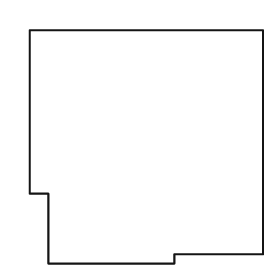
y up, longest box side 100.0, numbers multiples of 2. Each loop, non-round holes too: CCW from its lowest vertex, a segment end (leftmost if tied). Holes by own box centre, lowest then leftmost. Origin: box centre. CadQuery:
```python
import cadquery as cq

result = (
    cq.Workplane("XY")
    .moveTo(-42.0, -50.0)
    .lineTo(12.0, -50.0)
    .lineTo(12.0, -46.0)
    .lineTo(50.0, -46.0)
    .lineTo(50.0, 50.0)
    .lineTo(-50.0, 50.0)
    .lineTo(-50.0, -20.0)
    .lineTo(-42.0, -20.0)
    .close()
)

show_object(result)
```